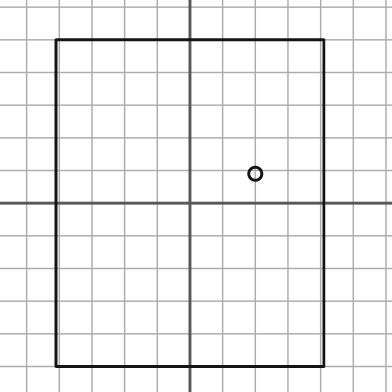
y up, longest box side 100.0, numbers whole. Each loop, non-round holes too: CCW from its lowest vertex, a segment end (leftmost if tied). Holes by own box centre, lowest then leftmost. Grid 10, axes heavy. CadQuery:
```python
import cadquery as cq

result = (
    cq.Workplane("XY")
    .moveTo(-41.0, -50.0)
    .lineTo(41.0, -50.0)
    .lineTo(41.0, 50.0)
    .lineTo(-41.0, 50.0)
    .close()
    .moveTo(20.0, 9.0)
    .circle(2.0)
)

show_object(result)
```